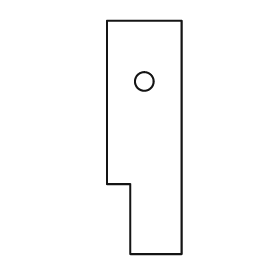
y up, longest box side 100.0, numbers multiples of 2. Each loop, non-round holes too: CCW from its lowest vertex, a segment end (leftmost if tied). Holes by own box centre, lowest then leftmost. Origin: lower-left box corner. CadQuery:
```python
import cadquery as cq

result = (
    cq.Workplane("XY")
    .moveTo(10.0, 0.0)
    .lineTo(32.0, 0.0)
    .lineTo(32.0, 100.0)
    .lineTo(0.0, 100.0)
    .lineTo(0.0, 30.0)
    .lineTo(10.0, 30.0)
    .close()
    .moveTo(16.0, 74.0)
    .circle(4.0)
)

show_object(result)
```